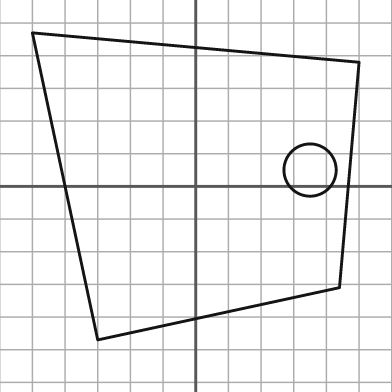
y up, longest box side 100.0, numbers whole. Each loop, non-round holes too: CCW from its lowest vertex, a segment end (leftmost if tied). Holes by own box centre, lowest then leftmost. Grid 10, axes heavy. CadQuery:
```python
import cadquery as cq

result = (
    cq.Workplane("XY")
    .moveTo(-30.0, -47.0)
    .lineTo(44.0, -31.0)
    .lineTo(50.0, 38.0)
    .lineTo(-50.0, 47.0)
    .close()
    .moveTo(35.0, 5.0)
    .circle(8.0)
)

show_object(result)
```